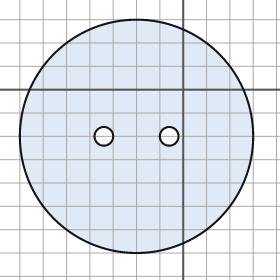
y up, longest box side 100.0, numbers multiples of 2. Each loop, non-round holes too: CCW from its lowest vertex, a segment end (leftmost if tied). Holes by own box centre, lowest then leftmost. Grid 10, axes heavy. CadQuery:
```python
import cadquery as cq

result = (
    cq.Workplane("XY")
    .moveTo(-20.0, -20.0)
    .circle(50.0)
    .moveTo(-34.0, -20.0)
    .circle(4.0)
    .moveTo(-6.0, -20.0)
    .circle(4.0)
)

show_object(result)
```